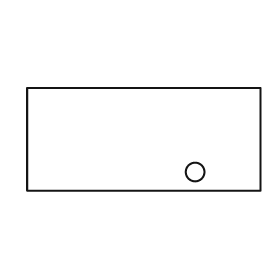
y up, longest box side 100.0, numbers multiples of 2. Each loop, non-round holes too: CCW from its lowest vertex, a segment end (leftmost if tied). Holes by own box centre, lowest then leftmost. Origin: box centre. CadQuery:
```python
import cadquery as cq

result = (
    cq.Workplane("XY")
    .moveTo(-50.0, -22.0)
    .lineTo(50.0, -22.0)
    .lineTo(50.0, 22.0)
    .lineTo(-50.0, 22.0)
    .close()
    .moveTo(22.0, -14.0)
    .circle(4.0)
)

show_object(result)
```